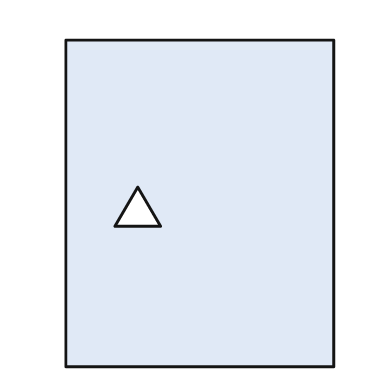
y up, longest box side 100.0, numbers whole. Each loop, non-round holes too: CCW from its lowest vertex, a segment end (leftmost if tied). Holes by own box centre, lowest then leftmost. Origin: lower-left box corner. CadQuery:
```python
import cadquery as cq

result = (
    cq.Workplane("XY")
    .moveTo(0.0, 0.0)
    .lineTo(82.0, 0.0)
    .lineTo(82.0, 100.0)
    .lineTo(0.0, 100.0)
    .close()
    .moveTo(15.0, 43.0)
    .lineTo(29.0, 43.0)
    .lineTo(22.0, 55.0)
    .close()
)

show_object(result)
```